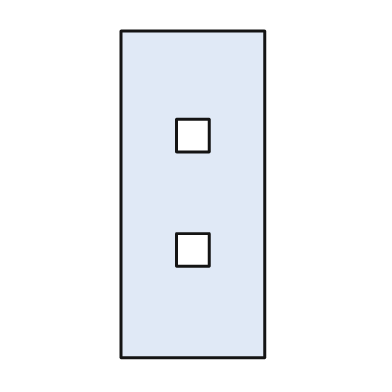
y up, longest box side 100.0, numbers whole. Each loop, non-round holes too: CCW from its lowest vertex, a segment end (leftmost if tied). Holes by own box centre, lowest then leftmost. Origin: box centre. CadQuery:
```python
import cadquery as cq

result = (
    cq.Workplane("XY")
    .moveTo(-22.0, -50.0)
    .lineTo(22.0, -50.0)
    .lineTo(22.0, 50.0)
    .lineTo(-22.0, 50.0)
    .close()
    .moveTo(-5.0, -22.0)
    .lineTo(5.0, -22.0)
    .lineTo(5.0, -12.0)
    .lineTo(-5.0, -12.0)
    .close()
    .moveTo(-5.0, 13.0)
    .lineTo(5.0, 13.0)
    .lineTo(5.0, 23.0)
    .lineTo(-5.0, 23.0)
    .close()
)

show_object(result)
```